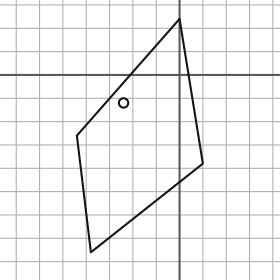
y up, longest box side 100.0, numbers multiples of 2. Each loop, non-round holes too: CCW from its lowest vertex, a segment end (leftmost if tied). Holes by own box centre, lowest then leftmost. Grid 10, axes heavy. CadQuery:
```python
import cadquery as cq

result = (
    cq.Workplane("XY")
    .moveTo(-38.0, -76.0)
    .lineTo(10.0, -38.0)
    .lineTo(0.0, 24.0)
    .lineTo(-44.0, -26.0)
    .close()
    .moveTo(-24.0, -12.0)
    .circle(2.0)
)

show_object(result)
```